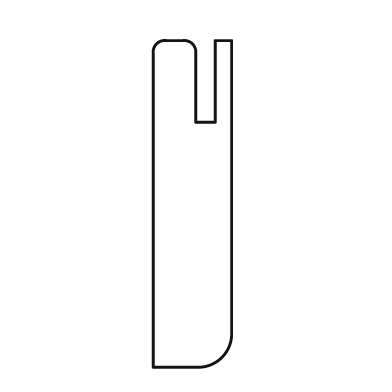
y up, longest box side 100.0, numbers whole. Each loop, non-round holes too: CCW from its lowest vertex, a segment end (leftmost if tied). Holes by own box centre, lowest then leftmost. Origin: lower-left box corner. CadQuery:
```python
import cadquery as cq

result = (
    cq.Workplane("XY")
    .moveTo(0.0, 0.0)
    .lineTo(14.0, 0.0)
    .threePointArc((21.0, 3.0), (24.0, 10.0))
    .lineTo(24.0, 100.0)
    .lineTo(19.0, 100.0)
    .lineTo(19.0, 75.0)
    .lineTo(13.0, 75.0)
    .lineTo(13.0, 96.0)
    .threePointArc((12.0, 99.0), (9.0, 100.0))
    .lineTo(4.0, 100.0)
    .threePointArc((1.0, 99.0), (0.0, 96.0))
    .close()
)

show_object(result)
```